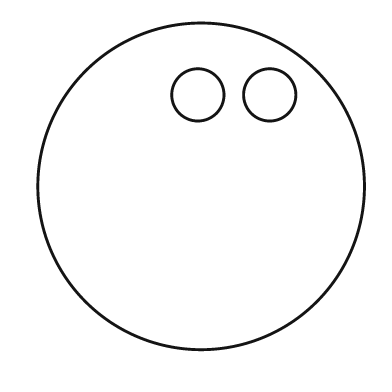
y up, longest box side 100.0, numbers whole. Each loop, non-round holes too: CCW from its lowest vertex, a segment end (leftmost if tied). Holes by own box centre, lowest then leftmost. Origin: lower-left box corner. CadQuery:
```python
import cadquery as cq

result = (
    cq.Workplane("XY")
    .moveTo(50.0, 50.0)
    .circle(50.0)
    .moveTo(49.0, 78.0)
    .circle(8.0)
    .moveTo(71.0, 78.0)
    .circle(8.0)
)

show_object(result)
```